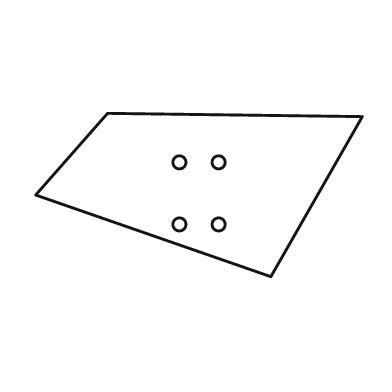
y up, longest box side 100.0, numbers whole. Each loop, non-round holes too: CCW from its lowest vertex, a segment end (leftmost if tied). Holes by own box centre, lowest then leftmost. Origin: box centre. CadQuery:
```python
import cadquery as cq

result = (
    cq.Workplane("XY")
    .moveTo(22.0, -25.0)
    .lineTo(50.0, 24.0)
    .lineTo(-28.0, 25.0)
    .lineTo(-50.0, 0.0)
    .close()
    .moveTo(-6.0, -9.0)
    .circle(2.0)
    .moveTo(6.0, -9.0)
    .circle(2.0)
    .moveTo(-6.0, 10.0)
    .circle(2.0)
    .moveTo(6.0, 10.0)
    .circle(2.0)
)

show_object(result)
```